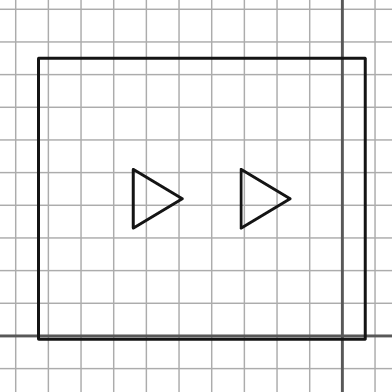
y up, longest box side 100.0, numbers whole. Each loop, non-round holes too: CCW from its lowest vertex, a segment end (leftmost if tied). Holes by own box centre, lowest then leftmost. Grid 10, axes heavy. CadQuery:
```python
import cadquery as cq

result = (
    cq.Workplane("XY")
    .moveTo(-93.0, -1.0)
    .lineTo(7.0, -1.0)
    .lineTo(7.0, 85.0)
    .lineTo(-93.0, 85.0)
    .close()
    .moveTo(-64.0, 33.0)
    .lineTo(-49.0, 42.0)
    .lineTo(-64.0, 51.0)
    .close()
    .moveTo(-31.0, 33.0)
    .lineTo(-16.0, 42.0)
    .lineTo(-31.0, 51.0)
    .close()
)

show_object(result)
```